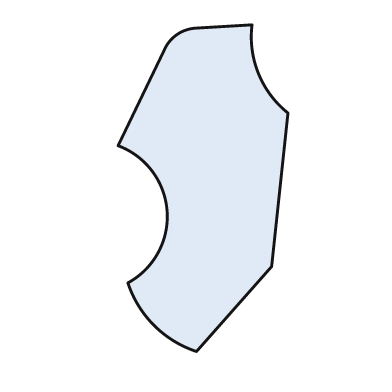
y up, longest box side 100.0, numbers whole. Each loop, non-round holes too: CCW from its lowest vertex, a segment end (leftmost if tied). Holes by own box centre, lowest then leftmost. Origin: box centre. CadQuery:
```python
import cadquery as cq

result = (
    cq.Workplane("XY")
    .moveTo(-2.0, -50.0)
    .lineTo(21.0, -24.0)
    .lineTo(26.0, 23.0)
    .threePointArc((17.0, 35.0), (15.0, 50.0))
    .lineTo(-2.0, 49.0)
    .threePointArc((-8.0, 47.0), (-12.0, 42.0))
    .lineTo(-26.0, 13.0)
    .threePointArc((-11.0, -7.0), (-23.0, -29.0))
    .threePointArc((-15.0, -42.0), (-2.0, -50.0))
    .close()
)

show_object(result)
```